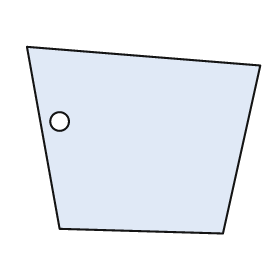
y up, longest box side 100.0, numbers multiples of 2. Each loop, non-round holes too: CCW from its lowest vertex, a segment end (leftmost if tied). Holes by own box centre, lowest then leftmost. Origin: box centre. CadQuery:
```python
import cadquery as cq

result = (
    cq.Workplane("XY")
    .moveTo(34.0, -40.0)
    .lineTo(50.0, 32.0)
    .lineTo(-50.0, 40.0)
    .lineTo(-36.0, -38.0)
    .close()
    .moveTo(-36.0, 8.0)
    .circle(4.0)
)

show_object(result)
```